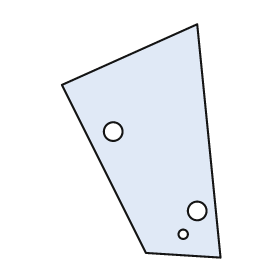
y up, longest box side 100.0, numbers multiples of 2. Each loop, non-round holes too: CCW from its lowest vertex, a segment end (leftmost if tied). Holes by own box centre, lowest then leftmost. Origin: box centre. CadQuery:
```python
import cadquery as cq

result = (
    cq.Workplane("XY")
    .moveTo(34.0, -50.0)
    .lineTo(24.0, 50.0)
    .lineTo(-34.0, 24.0)
    .lineTo(2.0, -48.0)
    .close()
    .moveTo(18.0, -40.0)
    .circle(2.0)
    .moveTo(24.0, -30.0)
    .circle(4.0)
    .moveTo(-12.0, 4.0)
    .circle(4.0)
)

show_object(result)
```